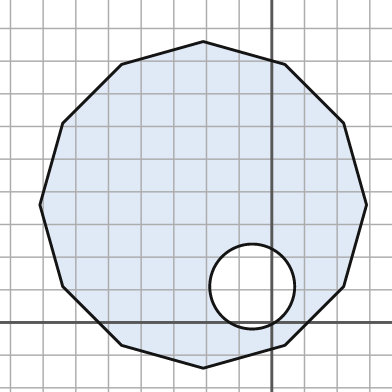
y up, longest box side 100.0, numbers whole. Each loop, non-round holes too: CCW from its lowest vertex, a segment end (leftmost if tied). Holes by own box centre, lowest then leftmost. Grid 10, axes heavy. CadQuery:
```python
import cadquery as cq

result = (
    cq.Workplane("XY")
    .moveTo(-21.0, -14.0)
    .lineTo(4.0, -7.0)
    .lineTo(22.0, 11.0)
    .lineTo(29.0, 36.0)
    .lineTo(22.0, 61.0)
    .lineTo(4.0, 79.0)
    .lineTo(-21.0, 86.0)
    .lineTo(-46.0, 79.0)
    .lineTo(-64.0, 61.0)
    .lineTo(-71.0, 36.0)
    .lineTo(-64.0, 11.0)
    .lineTo(-46.0, -7.0)
    .close()
    .moveTo(-6.0, 11.0)
    .circle(13.0)
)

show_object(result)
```